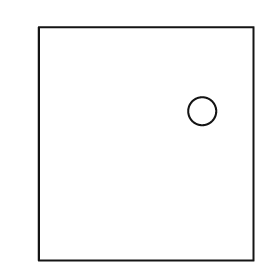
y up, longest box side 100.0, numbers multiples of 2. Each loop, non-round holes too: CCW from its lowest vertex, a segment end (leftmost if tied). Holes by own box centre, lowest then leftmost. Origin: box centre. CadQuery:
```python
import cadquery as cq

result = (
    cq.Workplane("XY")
    .moveTo(-46.0, -50.0)
    .lineTo(46.0, -50.0)
    .lineTo(46.0, 50.0)
    .lineTo(-46.0, 50.0)
    .close()
    .moveTo(24.0, 14.0)
    .circle(6.0)
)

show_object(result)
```